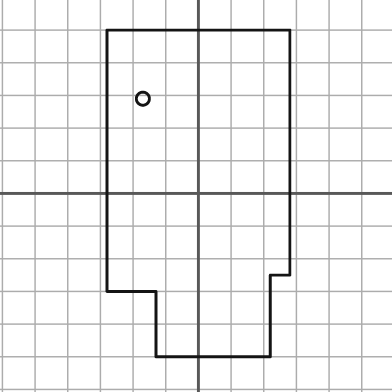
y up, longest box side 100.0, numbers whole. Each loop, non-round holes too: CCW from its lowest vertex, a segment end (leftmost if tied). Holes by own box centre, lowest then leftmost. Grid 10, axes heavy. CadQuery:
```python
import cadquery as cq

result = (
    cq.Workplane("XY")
    .moveTo(-13.0, -50.0)
    .lineTo(22.0, -50.0)
    .lineTo(22.0, -25.0)
    .lineTo(28.0, -25.0)
    .lineTo(28.0, 50.0)
    .lineTo(-28.0, 50.0)
    .lineTo(-28.0, -30.0)
    .lineTo(-13.0, -30.0)
    .close()
    .moveTo(-17.0, 29.0)
    .circle(2.0)
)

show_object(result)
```